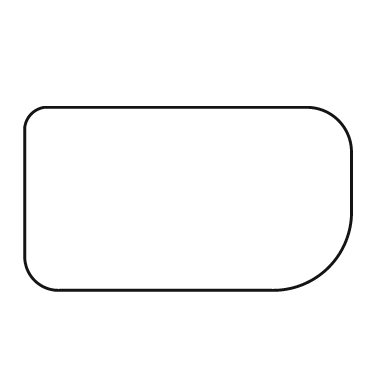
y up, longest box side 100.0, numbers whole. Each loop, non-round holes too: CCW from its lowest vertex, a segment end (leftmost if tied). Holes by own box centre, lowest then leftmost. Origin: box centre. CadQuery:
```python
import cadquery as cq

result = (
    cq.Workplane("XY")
    .moveTo(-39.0, -28.0)
    .lineTo(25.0, -28.0)
    .threePointArc((43.0, -21.0), (50.0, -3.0))
    .lineTo(50.0, 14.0)
    .threePointArc((46.0, 24.0), (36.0, 28.0))
    .lineTo(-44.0, 28.0)
    .threePointArc((-48.0, 26.0), (-50.0, 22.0))
    .lineTo(-50.0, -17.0)
    .threePointArc((-47.0, -25.0), (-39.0, -28.0))
    .close()
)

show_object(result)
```